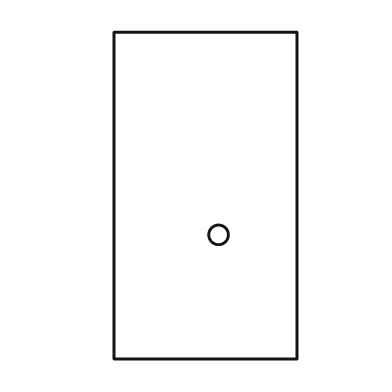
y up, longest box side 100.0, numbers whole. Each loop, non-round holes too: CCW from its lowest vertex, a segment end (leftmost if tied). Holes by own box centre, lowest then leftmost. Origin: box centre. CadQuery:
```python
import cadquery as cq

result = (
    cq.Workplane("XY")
    .moveTo(-28.0, -50.0)
    .lineTo(28.0, -50.0)
    .lineTo(28.0, 50.0)
    .lineTo(-28.0, 50.0)
    .close()
    .moveTo(4.0, -12.0)
    .circle(3.0)
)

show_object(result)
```